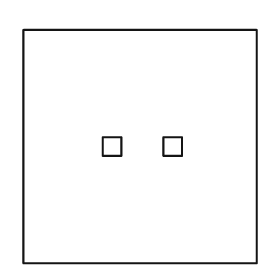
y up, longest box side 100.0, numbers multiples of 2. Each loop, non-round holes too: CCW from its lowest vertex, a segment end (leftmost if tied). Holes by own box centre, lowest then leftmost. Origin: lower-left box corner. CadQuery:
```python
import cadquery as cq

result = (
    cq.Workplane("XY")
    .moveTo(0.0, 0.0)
    .lineTo(100.0, 0.0)
    .lineTo(100.0, 100.0)
    .lineTo(0.0, 100.0)
    .close()
    .moveTo(34.0, 46.0)
    .lineTo(42.0, 46.0)
    .lineTo(42.0, 54.0)
    .lineTo(34.0, 54.0)
    .close()
    .moveTo(60.0, 46.0)
    .lineTo(68.0, 46.0)
    .lineTo(68.0, 54.0)
    .lineTo(60.0, 54.0)
    .close()
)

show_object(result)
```